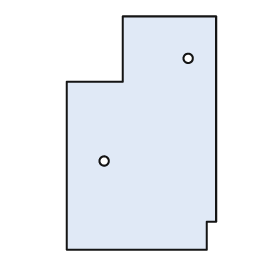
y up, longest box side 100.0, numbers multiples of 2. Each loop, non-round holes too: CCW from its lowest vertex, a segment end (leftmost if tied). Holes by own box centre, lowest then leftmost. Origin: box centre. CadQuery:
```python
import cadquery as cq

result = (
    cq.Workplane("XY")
    .moveTo(-32.0, -50.0)
    .lineTo(28.0, -50.0)
    .lineTo(28.0, -38.0)
    .lineTo(32.0, -38.0)
    .lineTo(32.0, 50.0)
    .lineTo(-8.0, 50.0)
    .lineTo(-8.0, 22.0)
    .lineTo(-32.0, 22.0)
    .close()
    .moveTo(-16.0, -12.0)
    .circle(2.0)
    .moveTo(20.0, 32.0)
    .circle(2.0)
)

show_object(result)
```